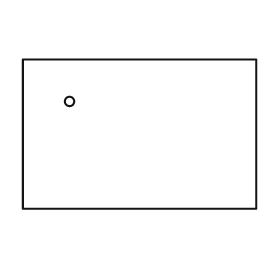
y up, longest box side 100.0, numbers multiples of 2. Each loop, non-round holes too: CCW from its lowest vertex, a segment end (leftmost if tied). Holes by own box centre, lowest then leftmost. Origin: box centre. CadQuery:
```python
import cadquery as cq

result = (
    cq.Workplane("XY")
    .moveTo(-50.0, -32.0)
    .lineTo(50.0, -32.0)
    .lineTo(50.0, 32.0)
    .lineTo(-50.0, 32.0)
    .close()
    .moveTo(-30.0, 14.0)
    .circle(2.0)
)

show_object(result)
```